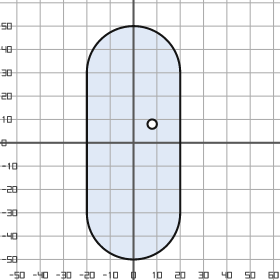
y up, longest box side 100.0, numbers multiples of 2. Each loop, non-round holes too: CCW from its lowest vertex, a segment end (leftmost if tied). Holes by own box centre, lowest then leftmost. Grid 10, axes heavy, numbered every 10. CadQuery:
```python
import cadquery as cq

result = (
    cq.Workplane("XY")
    .moveTo(-20.0, -30.0)
    .threePointArc((0.0, -50.0), (20.0, -30.0))
    .lineTo(20.0, 30.0)
    .threePointArc((0.0, 50.0), (-20.0, 30.0))
    .close()
    .moveTo(8.0, 8.0)
    .circle(2.0)
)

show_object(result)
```